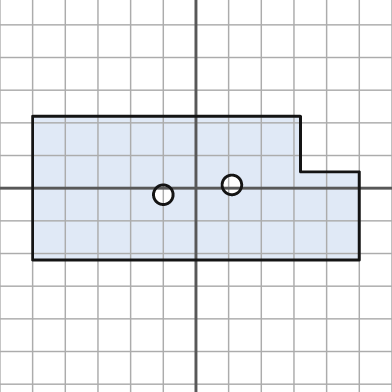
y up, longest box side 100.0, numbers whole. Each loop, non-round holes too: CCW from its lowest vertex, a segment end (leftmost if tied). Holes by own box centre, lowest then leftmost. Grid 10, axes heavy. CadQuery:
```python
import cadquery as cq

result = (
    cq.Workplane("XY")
    .moveTo(-50.0, -22.0)
    .lineTo(50.0, -22.0)
    .lineTo(50.0, 5.0)
    .lineTo(32.0, 5.0)
    .lineTo(32.0, 22.0)
    .lineTo(-50.0, 22.0)
    .close()
    .moveTo(-10.0, -2.0)
    .circle(3.0)
    .moveTo(11.0, 1.0)
    .circle(3.0)
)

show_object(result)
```